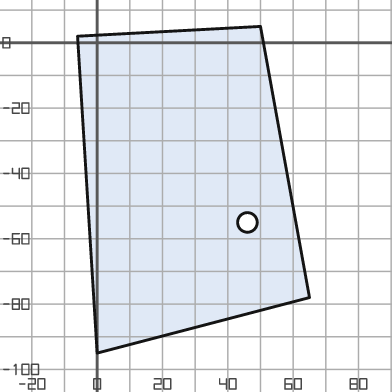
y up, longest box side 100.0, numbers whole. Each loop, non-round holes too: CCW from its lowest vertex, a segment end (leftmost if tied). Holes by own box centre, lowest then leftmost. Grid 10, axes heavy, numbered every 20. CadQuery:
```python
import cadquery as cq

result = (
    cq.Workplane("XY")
    .moveTo(0.0, -95.0)
    .lineTo(65.0, -78.0)
    .lineTo(50.0, 5.0)
    .lineTo(-6.0, 2.0)
    .close()
    .moveTo(46.0, -55.0)
    .circle(3.0)
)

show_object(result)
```